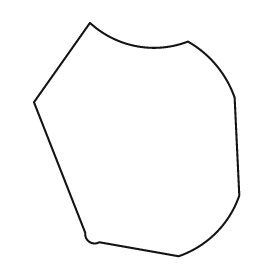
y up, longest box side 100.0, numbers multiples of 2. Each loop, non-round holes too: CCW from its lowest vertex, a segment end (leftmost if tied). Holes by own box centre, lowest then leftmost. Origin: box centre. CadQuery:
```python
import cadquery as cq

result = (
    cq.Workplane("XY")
    .moveTo(18.0, -50.0)
    .threePointArc((34.0, -40.0), (44.0, -24.0))
    .lineTo(42.0, 18.0)
    .threePointArc((34.0, 32.0), (22.0, 42.0))
    .threePointArc((0.0, 40.0), (-20.0, 50.0))
    .lineTo(-44.0, 16.0)
    .lineTo(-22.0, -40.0)
    .threePointArc((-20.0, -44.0), (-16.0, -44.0))
    .close()
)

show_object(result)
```